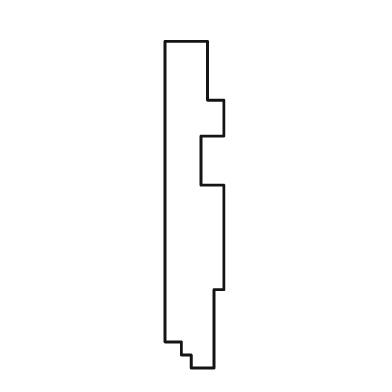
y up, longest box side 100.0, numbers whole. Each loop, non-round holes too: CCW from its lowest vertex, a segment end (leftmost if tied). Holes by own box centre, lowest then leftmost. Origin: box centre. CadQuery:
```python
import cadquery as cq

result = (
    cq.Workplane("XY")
    .moveTo(-1.0, -50.0)
    .lineTo(6.0, -50.0)
    .lineTo(6.0, -26.0)
    .lineTo(9.0, -26.0)
    .lineTo(9.0, 6.0)
    .lineTo(2.0, 6.0)
    .lineTo(2.0, 21.0)
    .lineTo(9.0, 21.0)
    .lineTo(9.0, 32.0)
    .lineTo(4.0, 32.0)
    .lineTo(4.0, 50.0)
    .lineTo(-9.0, 50.0)
    .lineTo(-9.0, -42.0)
    .lineTo(-4.0, -42.0)
    .lineTo(-4.0, -46.0)
    .lineTo(-1.0, -46.0)
    .close()
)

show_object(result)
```